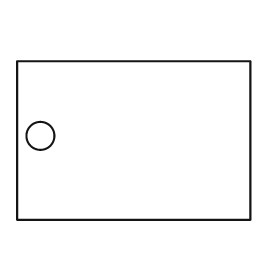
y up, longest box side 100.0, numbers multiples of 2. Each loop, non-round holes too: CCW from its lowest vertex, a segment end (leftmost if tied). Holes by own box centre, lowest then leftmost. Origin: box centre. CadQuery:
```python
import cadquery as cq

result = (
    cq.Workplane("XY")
    .moveTo(-50.0, -34.0)
    .lineTo(50.0, -34.0)
    .lineTo(50.0, 34.0)
    .lineTo(-50.0, 34.0)
    .close()
    .moveTo(-40.0, 2.0)
    .circle(6.0)
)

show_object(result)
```